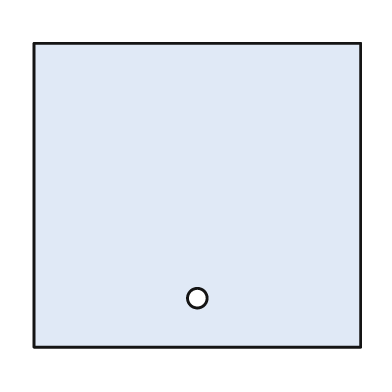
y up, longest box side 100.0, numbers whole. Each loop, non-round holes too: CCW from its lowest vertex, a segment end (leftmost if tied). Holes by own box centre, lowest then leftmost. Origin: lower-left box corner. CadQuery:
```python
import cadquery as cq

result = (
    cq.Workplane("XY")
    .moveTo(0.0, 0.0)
    .lineTo(100.0, 0.0)
    .lineTo(100.0, 93.0)
    .lineTo(0.0, 93.0)
    .close()
    .moveTo(50.0, 15.0)
    .circle(3.0)
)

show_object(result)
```